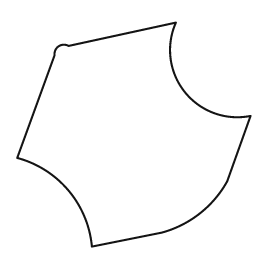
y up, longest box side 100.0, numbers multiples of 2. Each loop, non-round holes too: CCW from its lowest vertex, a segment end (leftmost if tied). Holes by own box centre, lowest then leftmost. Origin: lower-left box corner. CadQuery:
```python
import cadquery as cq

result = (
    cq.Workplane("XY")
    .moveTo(32.0, 0.0)
    .lineTo(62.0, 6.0)
    .threePointArc((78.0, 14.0), (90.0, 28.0))
    .lineTo(100.0, 56.0)
    .threePointArc((72.0, 66.0), (68.0, 96.0))
    .lineTo(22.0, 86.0)
    .threePointArc((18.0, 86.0), (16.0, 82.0))
    .lineTo(0.0, 38.0)
    .threePointArc((22.0, 24.0), (32.0, 0.0))
    .close()
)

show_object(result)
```